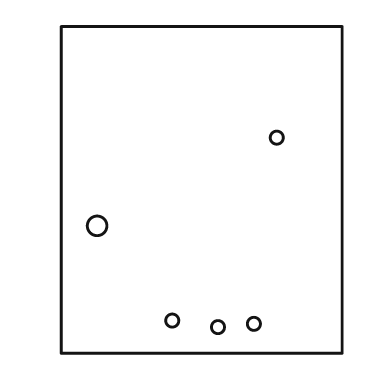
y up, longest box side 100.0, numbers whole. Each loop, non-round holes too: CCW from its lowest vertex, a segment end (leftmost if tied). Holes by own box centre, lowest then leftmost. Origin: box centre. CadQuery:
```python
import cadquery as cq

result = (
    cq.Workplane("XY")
    .moveTo(-43.0, -50.0)
    .lineTo(43.0, -50.0)
    .lineTo(43.0, 50.0)
    .lineTo(-43.0, 50.0)
    .close()
    .moveTo(5.0, -42.0)
    .circle(2.0)
    .moveTo(16.0, -41.0)
    .circle(2.0)
    .moveTo(-9.0, -40.0)
    .circle(2.0)
    .moveTo(-32.0, -11.0)
    .circle(3.0)
    .moveTo(23.0, 16.0)
    .circle(2.0)
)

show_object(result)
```